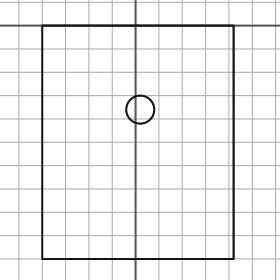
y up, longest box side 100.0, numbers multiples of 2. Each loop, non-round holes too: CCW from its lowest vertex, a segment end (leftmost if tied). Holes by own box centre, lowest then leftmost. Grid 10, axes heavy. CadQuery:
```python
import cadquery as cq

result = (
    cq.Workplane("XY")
    .moveTo(-40.0, -100.0)
    .lineTo(42.0, -100.0)
    .lineTo(42.0, 0.0)
    .lineTo(-40.0, 0.0)
    .close()
    .moveTo(2.0, -36.0)
    .circle(6.0)
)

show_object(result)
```